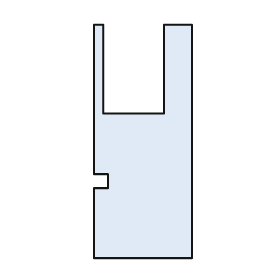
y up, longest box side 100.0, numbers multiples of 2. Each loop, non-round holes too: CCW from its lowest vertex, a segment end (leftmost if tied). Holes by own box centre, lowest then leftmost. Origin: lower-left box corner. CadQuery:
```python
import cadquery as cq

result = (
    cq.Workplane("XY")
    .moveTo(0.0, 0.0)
    .lineTo(42.0, 0.0)
    .lineTo(42.0, 100.0)
    .lineTo(30.0, 100.0)
    .lineTo(30.0, 62.0)
    .lineTo(4.0, 62.0)
    .lineTo(4.0, 100.0)
    .lineTo(0.0, 100.0)
    .lineTo(0.0, 36.0)
    .lineTo(6.0, 36.0)
    .lineTo(6.0, 30.0)
    .lineTo(0.0, 30.0)
    .close()
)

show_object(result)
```